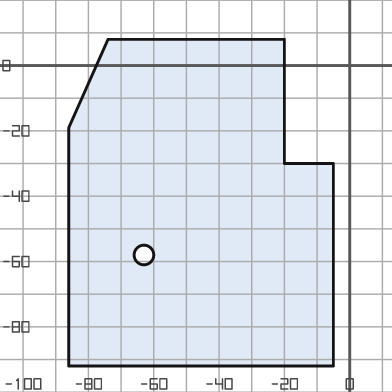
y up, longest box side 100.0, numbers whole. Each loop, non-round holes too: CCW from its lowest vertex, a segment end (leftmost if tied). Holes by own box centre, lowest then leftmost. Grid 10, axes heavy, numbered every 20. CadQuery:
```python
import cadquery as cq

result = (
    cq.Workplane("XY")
    .moveTo(-86.0, -92.0)
    .lineTo(-5.0, -92.0)
    .lineTo(-5.0, -30.0)
    .lineTo(-20.0, -30.0)
    .lineTo(-20.0, 8.0)
    .lineTo(-74.0, 8.0)
    .lineTo(-86.0, -19.0)
    .close()
    .moveTo(-63.0, -58.0)
    .circle(3.0)
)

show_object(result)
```